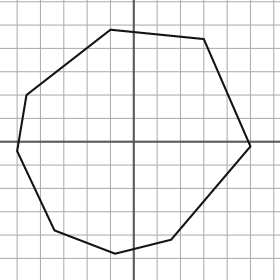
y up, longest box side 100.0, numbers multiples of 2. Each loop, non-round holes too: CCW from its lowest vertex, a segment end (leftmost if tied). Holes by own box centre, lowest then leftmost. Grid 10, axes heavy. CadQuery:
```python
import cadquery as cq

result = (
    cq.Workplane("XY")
    .moveTo(-8.0, -48.0)
    .lineTo(16.0, -42.0)
    .lineTo(50.0, -2.0)
    .lineTo(30.0, 44.0)
    .lineTo(-10.0, 48.0)
    .lineTo(-46.0, 20.0)
    .lineTo(-50.0, -4.0)
    .lineTo(-34.0, -38.0)
    .close()
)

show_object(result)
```